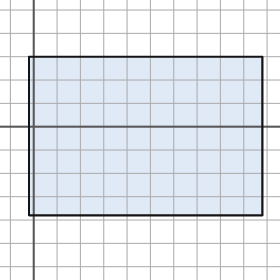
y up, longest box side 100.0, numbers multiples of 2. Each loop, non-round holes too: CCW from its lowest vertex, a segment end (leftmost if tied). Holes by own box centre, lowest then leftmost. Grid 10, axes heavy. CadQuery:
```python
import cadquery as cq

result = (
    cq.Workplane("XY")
    .moveTo(-2.0, -38.0)
    .lineTo(98.0, -38.0)
    .lineTo(98.0, 30.0)
    .lineTo(-2.0, 30.0)
    .close()
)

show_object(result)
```